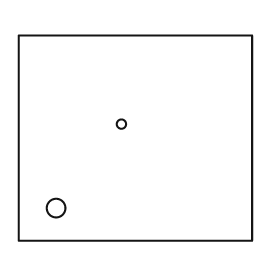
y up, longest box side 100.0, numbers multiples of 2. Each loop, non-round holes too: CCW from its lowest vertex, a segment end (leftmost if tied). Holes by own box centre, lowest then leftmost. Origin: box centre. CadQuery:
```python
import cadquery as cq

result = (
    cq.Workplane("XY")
    .moveTo(-50.0, -44.0)
    .lineTo(50.0, -44.0)
    .lineTo(50.0, 44.0)
    .lineTo(-50.0, 44.0)
    .close()
    .moveTo(-34.0, -30.0)
    .circle(4.0)
    .moveTo(-6.0, 6.0)
    .circle(2.0)
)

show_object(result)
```